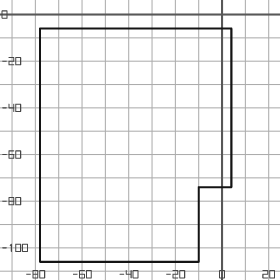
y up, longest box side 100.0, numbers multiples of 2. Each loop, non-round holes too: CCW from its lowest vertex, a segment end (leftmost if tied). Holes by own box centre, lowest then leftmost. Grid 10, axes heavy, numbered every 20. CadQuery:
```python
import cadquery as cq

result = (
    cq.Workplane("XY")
    .moveTo(-78.0, -106.0)
    .lineTo(-10.0, -106.0)
    .lineTo(-10.0, -74.0)
    .lineTo(4.0, -74.0)
    .lineTo(4.0, -6.0)
    .lineTo(-78.0, -6.0)
    .close()
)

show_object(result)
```